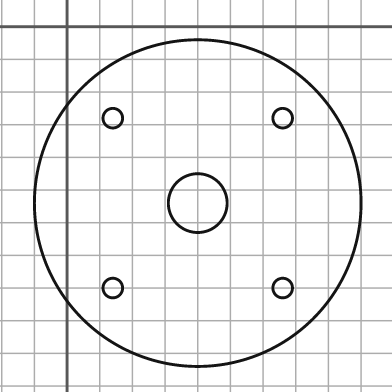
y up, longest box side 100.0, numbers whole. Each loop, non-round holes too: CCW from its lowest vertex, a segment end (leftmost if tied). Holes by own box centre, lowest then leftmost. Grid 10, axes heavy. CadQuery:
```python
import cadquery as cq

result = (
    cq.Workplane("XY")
    .moveTo(40.0, -54.0)
    .circle(50.0)
    .moveTo(14.0, -80.0)
    .circle(3.0)
    .moveTo(66.0, -80.0)
    .circle(3.0)
    .moveTo(40.0, -54.0)
    .circle(9.0)
    .moveTo(14.0, -28.0)
    .circle(3.0)
    .moveTo(66.0, -28.0)
    .circle(3.0)
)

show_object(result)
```